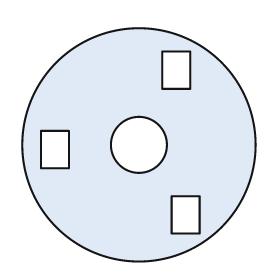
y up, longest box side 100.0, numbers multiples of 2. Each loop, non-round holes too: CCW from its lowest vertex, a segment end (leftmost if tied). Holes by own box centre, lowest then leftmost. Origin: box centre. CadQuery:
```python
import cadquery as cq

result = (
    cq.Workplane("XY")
    .moveTo(0.0, 0.0)
    .circle(50.0)
    .moveTo(14.0, -38.0)
    .lineTo(26.0, -38.0)
    .lineTo(26.0, -22.0)
    .lineTo(14.0, -22.0)
    .close()
    .moveTo(-42.0, -10.0)
    .lineTo(-30.0, -10.0)
    .lineTo(-30.0, 6.0)
    .lineTo(-42.0, 6.0)
    .close()
    .moveTo(0.0, 0.0)
    .circle(12.0)
    .moveTo(10.0, 24.0)
    .lineTo(22.0, 24.0)
    .lineTo(22.0, 40.0)
    .lineTo(10.0, 40.0)
    .close()
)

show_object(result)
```